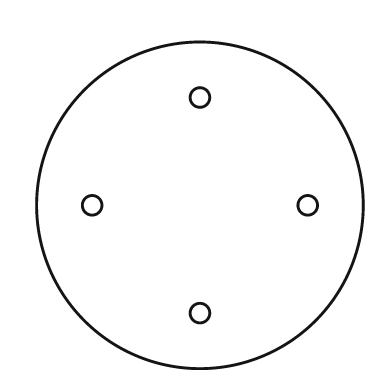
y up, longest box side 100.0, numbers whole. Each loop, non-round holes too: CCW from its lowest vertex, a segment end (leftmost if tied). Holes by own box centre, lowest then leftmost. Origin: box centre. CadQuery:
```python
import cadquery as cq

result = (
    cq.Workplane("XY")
    .moveTo(0.0, 0.0)
    .circle(50.0)
    .moveTo(0.0, -33.0)
    .circle(3.0)
    .moveTo(-33.0, 0.0)
    .circle(3.0)
    .moveTo(33.0, 0.0)
    .circle(3.0)
    .moveTo(0.0, 33.0)
    .circle(3.0)
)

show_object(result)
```